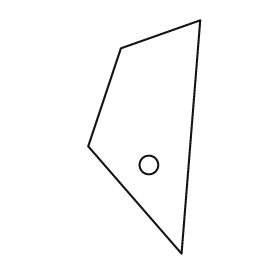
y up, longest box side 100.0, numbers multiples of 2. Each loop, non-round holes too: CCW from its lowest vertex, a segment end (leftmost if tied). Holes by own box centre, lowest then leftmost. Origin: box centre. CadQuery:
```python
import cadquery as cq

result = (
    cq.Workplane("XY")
    .moveTo(16.0, -50.0)
    .lineTo(24.0, 50.0)
    .lineTo(-10.0, 38.0)
    .lineTo(-24.0, -4.0)
    .close()
    .moveTo(2.0, -12.0)
    .circle(4.0)
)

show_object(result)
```